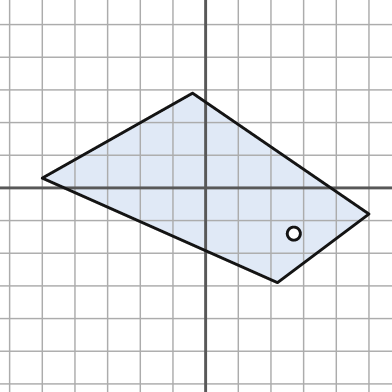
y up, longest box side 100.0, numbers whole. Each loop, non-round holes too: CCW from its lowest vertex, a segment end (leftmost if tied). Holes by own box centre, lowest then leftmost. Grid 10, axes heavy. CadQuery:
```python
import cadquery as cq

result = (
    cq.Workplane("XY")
    .moveTo(22.0, -29.0)
    .lineTo(50.0, -8.0)
    .lineTo(-4.0, 29.0)
    .lineTo(-50.0, 3.0)
    .close()
    .moveTo(27.0, -14.0)
    .circle(2.0)
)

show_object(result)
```